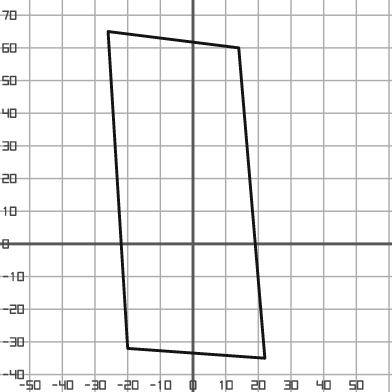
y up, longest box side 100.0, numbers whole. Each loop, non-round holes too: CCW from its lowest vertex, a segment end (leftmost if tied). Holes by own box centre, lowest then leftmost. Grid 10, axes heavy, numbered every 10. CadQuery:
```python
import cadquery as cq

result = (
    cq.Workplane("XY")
    .moveTo(22.0, -35.0)
    .lineTo(14.0, 60.0)
    .lineTo(-26.0, 65.0)
    .lineTo(-20.0, -32.0)
    .close()
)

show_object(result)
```